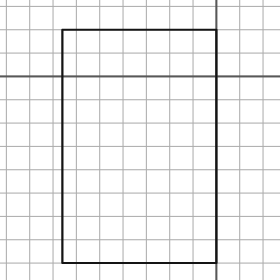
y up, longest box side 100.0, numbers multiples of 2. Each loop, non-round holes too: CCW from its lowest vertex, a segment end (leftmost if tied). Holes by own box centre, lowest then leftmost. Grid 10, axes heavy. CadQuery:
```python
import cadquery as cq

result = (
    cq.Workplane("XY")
    .moveTo(-66.0, -80.0)
    .lineTo(0.0, -80.0)
    .lineTo(0.0, 20.0)
    .lineTo(-66.0, 20.0)
    .close()
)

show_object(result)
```